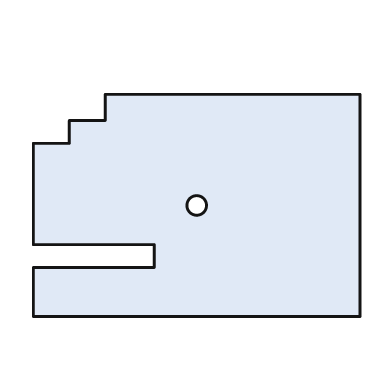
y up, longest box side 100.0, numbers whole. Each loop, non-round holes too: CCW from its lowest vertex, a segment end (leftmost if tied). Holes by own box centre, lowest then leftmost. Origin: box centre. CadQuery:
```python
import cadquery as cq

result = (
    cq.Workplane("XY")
    .moveTo(-50.0, -34.0)
    .lineTo(50.0, -34.0)
    .lineTo(50.0, 34.0)
    .lineTo(-28.0, 34.0)
    .lineTo(-28.0, 26.0)
    .lineTo(-39.0, 26.0)
    .lineTo(-39.0, 19.0)
    .lineTo(-50.0, 19.0)
    .lineTo(-50.0, -12.0)
    .lineTo(-13.0, -12.0)
    .lineTo(-13.0, -19.0)
    .lineTo(-50.0, -19.0)
    .close()
    .moveTo(0.0, 0.0)
    .circle(3.0)
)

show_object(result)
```